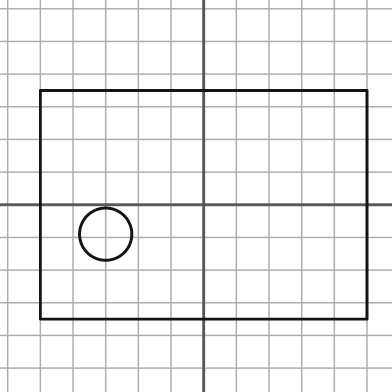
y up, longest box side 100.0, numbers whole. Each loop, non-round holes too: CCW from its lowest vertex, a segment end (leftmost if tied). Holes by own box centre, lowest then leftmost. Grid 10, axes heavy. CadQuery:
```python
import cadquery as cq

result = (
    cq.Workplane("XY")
    .moveTo(-50.0, -35.0)
    .lineTo(50.0, -35.0)
    .lineTo(50.0, 35.0)
    .lineTo(-50.0, 35.0)
    .close()
    .moveTo(-30.0, -9.0)
    .circle(8.0)
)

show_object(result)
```